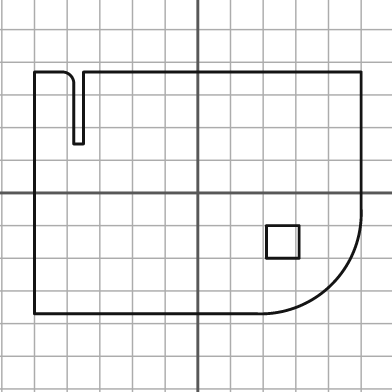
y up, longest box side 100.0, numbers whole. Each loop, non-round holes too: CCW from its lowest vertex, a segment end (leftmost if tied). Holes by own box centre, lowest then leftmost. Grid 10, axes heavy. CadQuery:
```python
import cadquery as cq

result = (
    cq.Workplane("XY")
    .moveTo(-50.0, -37.0)
    .lineTo(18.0, -37.0)
    .threePointArc((41.0, -28.0), (50.0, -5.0))
    .lineTo(50.0, 37.0)
    .lineTo(-35.0, 37.0)
    .lineTo(-35.0, 15.0)
    .lineTo(-38.0, 15.0)
    .lineTo(-38.0, 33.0)
    .threePointArc((-39.0, 36.0), (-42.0, 37.0))
    .lineTo(-50.0, 37.0)
    .close()
    .moveTo(21.0, -20.0)
    .lineTo(31.0, -20.0)
    .lineTo(31.0, -10.0)
    .lineTo(21.0, -10.0)
    .close()
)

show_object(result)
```